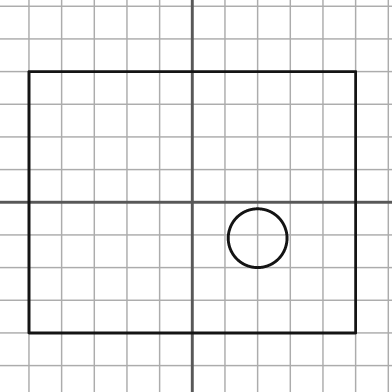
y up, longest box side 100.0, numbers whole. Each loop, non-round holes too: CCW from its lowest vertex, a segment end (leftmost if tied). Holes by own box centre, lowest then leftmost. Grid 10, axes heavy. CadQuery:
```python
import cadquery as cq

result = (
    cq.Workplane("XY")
    .moveTo(-50.0, -40.0)
    .lineTo(50.0, -40.0)
    .lineTo(50.0, 40.0)
    .lineTo(-50.0, 40.0)
    .close()
    .moveTo(20.0, -11.0)
    .circle(9.0)
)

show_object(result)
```